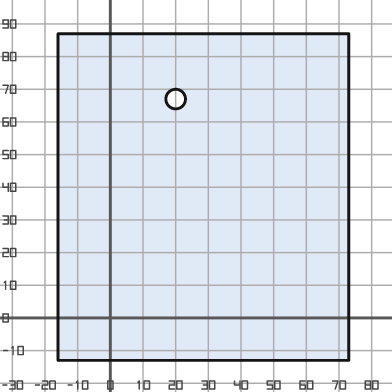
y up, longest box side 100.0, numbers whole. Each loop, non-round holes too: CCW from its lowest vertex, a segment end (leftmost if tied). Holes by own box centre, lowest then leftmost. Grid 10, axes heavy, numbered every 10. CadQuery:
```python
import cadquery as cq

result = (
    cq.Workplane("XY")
    .moveTo(-16.0, -13.0)
    .lineTo(73.0, -13.0)
    .lineTo(73.0, 87.0)
    .lineTo(-16.0, 87.0)
    .close()
    .moveTo(20.0, 67.0)
    .circle(3.0)
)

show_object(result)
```